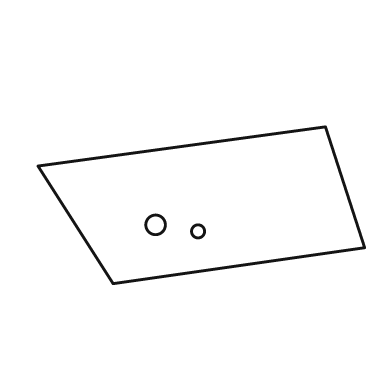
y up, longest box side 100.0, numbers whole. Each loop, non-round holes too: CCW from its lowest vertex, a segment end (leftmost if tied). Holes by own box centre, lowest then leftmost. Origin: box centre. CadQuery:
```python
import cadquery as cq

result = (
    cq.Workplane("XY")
    .moveTo(-27.0, -24.0)
    .lineTo(50.0, -13.0)
    .lineTo(38.0, 24.0)
    .lineTo(-50.0, 12.0)
    .close()
    .moveTo(-1.0, -8.0)
    .circle(2.0)
    .moveTo(-14.0, -6.0)
    .circle(3.0)
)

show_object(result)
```